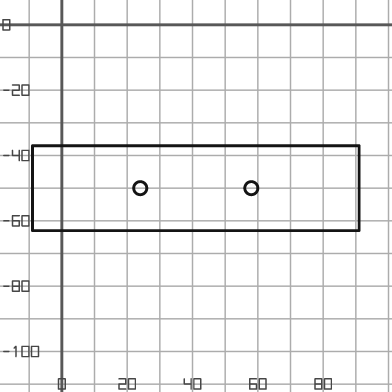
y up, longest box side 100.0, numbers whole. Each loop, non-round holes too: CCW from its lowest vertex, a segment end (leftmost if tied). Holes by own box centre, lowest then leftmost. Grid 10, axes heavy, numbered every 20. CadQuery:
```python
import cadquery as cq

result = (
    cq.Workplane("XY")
    .moveTo(-9.0, -63.0)
    .lineTo(91.0, -63.0)
    .lineTo(91.0, -37.0)
    .lineTo(-9.0, -37.0)
    .close()
    .moveTo(24.0, -50.0)
    .circle(2.0)
    .moveTo(58.0, -50.0)
    .circle(2.0)
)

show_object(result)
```